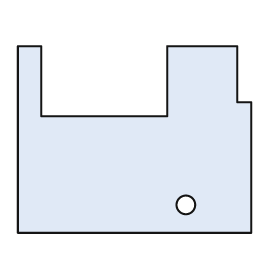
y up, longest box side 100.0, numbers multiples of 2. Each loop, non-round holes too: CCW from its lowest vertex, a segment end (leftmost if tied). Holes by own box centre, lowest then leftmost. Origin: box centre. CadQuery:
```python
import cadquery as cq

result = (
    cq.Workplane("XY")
    .moveTo(-50.0, -40.0)
    .lineTo(50.0, -40.0)
    .lineTo(50.0, 16.0)
    .lineTo(44.0, 16.0)
    .lineTo(44.0, 40.0)
    .lineTo(14.0, 40.0)
    .lineTo(14.0, 10.0)
    .lineTo(-40.0, 10.0)
    .lineTo(-40.0, 40.0)
    .lineTo(-50.0, 40.0)
    .close()
    .moveTo(22.0, -28.0)
    .circle(4.0)
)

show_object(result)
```